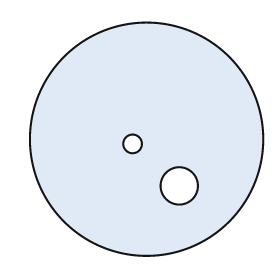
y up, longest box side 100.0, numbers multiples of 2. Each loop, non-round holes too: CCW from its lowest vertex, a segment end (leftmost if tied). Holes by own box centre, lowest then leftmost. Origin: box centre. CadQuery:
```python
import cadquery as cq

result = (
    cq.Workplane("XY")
    .moveTo(0.0, 0.0)
    .circle(50.0)
    .moveTo(14.0, -20.0)
    .circle(8.0)
    .moveTo(-6.0, -2.0)
    .circle(4.0)
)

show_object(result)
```